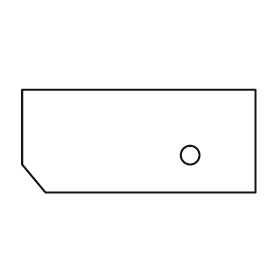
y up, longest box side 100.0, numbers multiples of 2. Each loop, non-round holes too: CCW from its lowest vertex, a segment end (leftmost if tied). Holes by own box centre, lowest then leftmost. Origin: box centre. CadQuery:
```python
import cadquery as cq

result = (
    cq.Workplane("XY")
    .moveTo(-40.0, -22.0)
    .lineTo(50.0, -22.0)
    .lineTo(50.0, 22.0)
    .lineTo(-50.0, 22.0)
    .lineTo(-50.0, -10.0)
    .close()
    .moveTo(22.0, -6.0)
    .circle(4.0)
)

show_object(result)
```